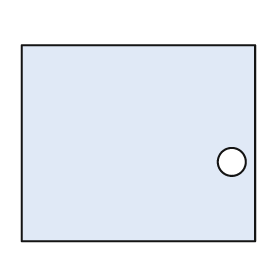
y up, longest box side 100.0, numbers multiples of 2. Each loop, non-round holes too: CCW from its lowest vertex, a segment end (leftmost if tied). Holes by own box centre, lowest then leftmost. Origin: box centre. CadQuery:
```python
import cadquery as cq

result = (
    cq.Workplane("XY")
    .moveTo(-50.0, -42.0)
    .lineTo(50.0, -42.0)
    .lineTo(50.0, 42.0)
    .lineTo(-50.0, 42.0)
    .close()
    .moveTo(40.0, -8.0)
    .circle(6.0)
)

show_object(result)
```